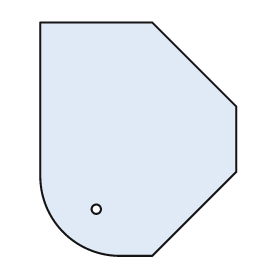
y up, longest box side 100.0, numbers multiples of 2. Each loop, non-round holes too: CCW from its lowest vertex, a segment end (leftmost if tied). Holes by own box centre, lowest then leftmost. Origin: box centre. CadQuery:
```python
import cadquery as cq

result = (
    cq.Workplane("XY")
    .moveTo(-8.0, -50.0)
    .lineTo(6.0, -50.0)
    .lineTo(42.0, -14.0)
    .lineTo(42.0, 14.0)
    .lineTo(6.0, 50.0)
    .lineTo(-42.0, 50.0)
    .lineTo(-42.0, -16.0)
    .threePointArc((-32.0, -40.0), (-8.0, -50.0))
    .close()
    .moveTo(-18.0, -30.0)
    .circle(2.0)
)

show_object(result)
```